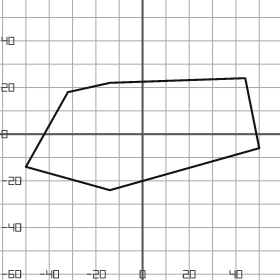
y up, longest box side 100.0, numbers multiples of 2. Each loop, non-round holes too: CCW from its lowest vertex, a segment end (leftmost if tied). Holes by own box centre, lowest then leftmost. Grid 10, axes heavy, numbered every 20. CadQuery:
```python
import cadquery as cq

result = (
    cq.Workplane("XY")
    .moveTo(-14.0, -24.0)
    .lineTo(50.0, -6.0)
    .lineTo(44.0, 24.0)
    .lineTo(-14.0, 22.0)
    .lineTo(-32.0, 18.0)
    .lineTo(-50.0, -14.0)
    .close()
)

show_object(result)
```